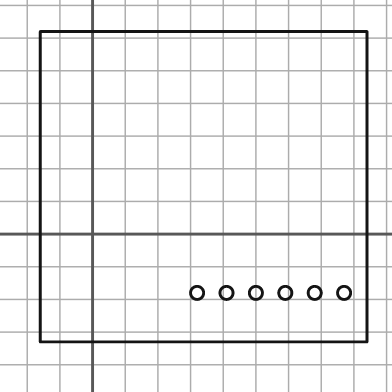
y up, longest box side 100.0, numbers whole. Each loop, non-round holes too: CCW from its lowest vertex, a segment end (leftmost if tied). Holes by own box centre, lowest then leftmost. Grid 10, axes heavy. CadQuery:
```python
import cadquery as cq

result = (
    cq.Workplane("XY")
    .moveTo(-16.0, -33.0)
    .lineTo(84.0, -33.0)
    .lineTo(84.0, 62.0)
    .lineTo(-16.0, 62.0)
    .close()
    .moveTo(32.0, -18.0)
    .circle(2.0)
    .moveTo(41.0, -18.0)
    .circle(2.0)
    .moveTo(50.0, -18.0)
    .circle(2.0)
    .moveTo(59.0, -18.0)
    .circle(2.0)
    .moveTo(68.0, -18.0)
    .circle(2.0)
    .moveTo(77.0, -18.0)
    .circle(2.0)
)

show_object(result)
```